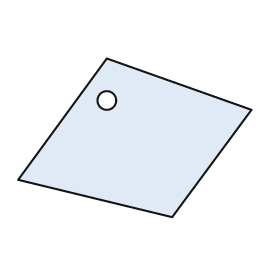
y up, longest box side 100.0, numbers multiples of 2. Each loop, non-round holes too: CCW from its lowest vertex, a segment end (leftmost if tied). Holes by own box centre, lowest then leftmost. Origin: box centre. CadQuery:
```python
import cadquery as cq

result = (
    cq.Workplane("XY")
    .moveTo(16.0, -34.0)
    .lineTo(50.0, 12.0)
    .lineTo(-12.0, 34.0)
    .lineTo(-50.0, -18.0)
    .close()
    .moveTo(-12.0, 16.0)
    .circle(4.0)
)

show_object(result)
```